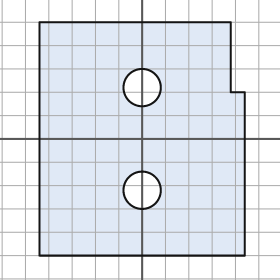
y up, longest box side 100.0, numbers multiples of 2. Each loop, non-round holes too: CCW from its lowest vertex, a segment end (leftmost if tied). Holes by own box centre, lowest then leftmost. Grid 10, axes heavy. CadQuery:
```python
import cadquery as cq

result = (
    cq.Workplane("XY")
    .moveTo(-44.0, -50.0)
    .lineTo(44.0, -50.0)
    .lineTo(44.0, 20.0)
    .lineTo(38.0, 20.0)
    .lineTo(38.0, 50.0)
    .lineTo(-44.0, 50.0)
    .close()
    .moveTo(0.0, -22.0)
    .circle(8.0)
    .moveTo(0.0, 22.0)
    .circle(8.0)
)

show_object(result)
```